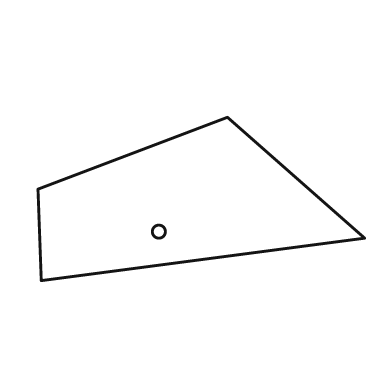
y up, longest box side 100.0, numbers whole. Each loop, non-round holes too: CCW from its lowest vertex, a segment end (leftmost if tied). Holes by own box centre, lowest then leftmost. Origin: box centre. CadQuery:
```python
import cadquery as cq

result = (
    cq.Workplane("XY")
    .moveTo(-49.0, -25.0)
    .lineTo(50.0, -12.0)
    .lineTo(8.0, 25.0)
    .lineTo(-50.0, 3.0)
    .close()
    .moveTo(-13.0, -10.0)
    .circle(2.0)
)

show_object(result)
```